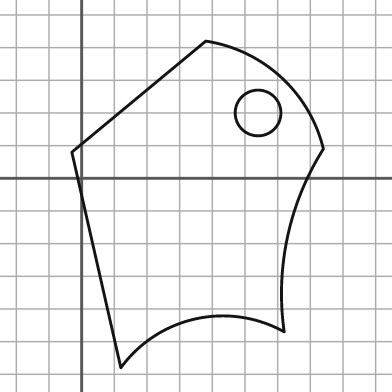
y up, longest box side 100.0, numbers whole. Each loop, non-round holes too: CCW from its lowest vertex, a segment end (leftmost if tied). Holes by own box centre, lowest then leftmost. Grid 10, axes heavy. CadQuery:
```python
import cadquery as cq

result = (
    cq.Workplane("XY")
    .moveTo(12.0, -58.0)
    .threePointArc((35.0, -43.0), (62.0, -47.0))
    .threePointArc((63.0, -18.0), (74.0, 9.0))
    .threePointArc((61.0, 31.0), (38.0, 42.0))
    .lineTo(-3.0, 8.0)
    .close()
    .moveTo(54.0, 20.0)
    .circle(7.0)
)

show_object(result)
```